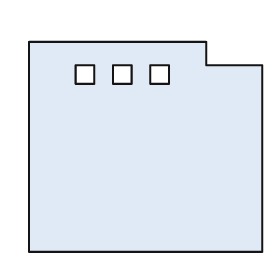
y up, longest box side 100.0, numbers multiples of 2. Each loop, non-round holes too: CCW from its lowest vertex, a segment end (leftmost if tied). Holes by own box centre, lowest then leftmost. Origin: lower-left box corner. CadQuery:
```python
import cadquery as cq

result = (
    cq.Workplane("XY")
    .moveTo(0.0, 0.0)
    .lineTo(100.0, 0.0)
    .lineTo(100.0, 80.0)
    .lineTo(76.0, 80.0)
    .lineTo(76.0, 90.0)
    .lineTo(0.0, 90.0)
    .close()
    .moveTo(20.0, 72.0)
    .lineTo(28.0, 72.0)
    .lineTo(28.0, 80.0)
    .lineTo(20.0, 80.0)
    .close()
    .moveTo(36.0, 72.0)
    .lineTo(44.0, 72.0)
    .lineTo(44.0, 80.0)
    .lineTo(36.0, 80.0)
    .close()
    .moveTo(52.0, 72.0)
    .lineTo(60.0, 72.0)
    .lineTo(60.0, 80.0)
    .lineTo(52.0, 80.0)
    .close()
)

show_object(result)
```